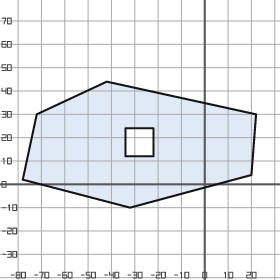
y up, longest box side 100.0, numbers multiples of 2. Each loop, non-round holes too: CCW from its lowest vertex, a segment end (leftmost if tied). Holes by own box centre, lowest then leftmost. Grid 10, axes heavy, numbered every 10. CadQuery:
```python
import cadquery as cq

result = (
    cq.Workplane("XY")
    .moveTo(-32.0, -10.0)
    .lineTo(20.0, 4.0)
    .lineTo(22.0, 30.0)
    .lineTo(-42.0, 44.0)
    .lineTo(-72.0, 30.0)
    .lineTo(-78.0, 2.0)
    .close()
    .moveTo(-34.0, 12.0)
    .lineTo(-22.0, 12.0)
    .lineTo(-22.0, 24.0)
    .lineTo(-34.0, 24.0)
    .close()
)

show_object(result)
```